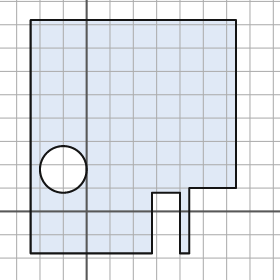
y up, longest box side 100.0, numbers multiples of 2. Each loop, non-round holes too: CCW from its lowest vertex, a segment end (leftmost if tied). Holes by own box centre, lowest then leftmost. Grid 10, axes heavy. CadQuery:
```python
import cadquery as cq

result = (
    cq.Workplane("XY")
    .moveTo(-24.0, -18.0)
    .lineTo(28.0, -18.0)
    .lineTo(28.0, 8.0)
    .lineTo(40.0, 8.0)
    .lineTo(40.0, -18.0)
    .lineTo(44.0, -18.0)
    .lineTo(44.0, 10.0)
    .lineTo(64.0, 10.0)
    .lineTo(64.0, 82.0)
    .lineTo(-24.0, 82.0)
    .close()
    .moveTo(-10.0, 18.0)
    .circle(10.0)
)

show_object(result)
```